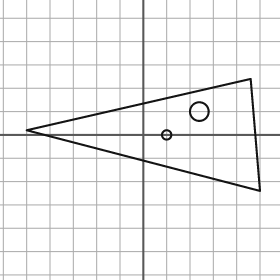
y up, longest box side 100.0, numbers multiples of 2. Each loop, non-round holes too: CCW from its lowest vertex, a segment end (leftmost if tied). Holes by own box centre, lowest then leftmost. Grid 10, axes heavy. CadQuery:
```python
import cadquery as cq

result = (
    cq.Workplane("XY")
    .moveTo(50.0, -24.0)
    .lineTo(46.0, 24.0)
    .lineTo(-50.0, 2.0)
    .close()
    .moveTo(10.0, 0.0)
    .circle(2.0)
    .moveTo(24.0, 10.0)
    .circle(4.0)
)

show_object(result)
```